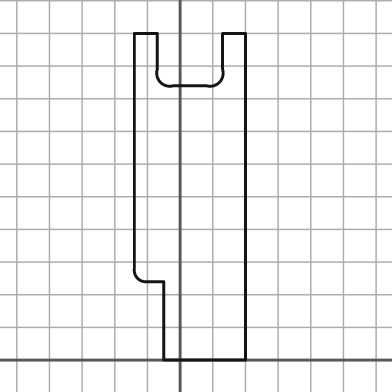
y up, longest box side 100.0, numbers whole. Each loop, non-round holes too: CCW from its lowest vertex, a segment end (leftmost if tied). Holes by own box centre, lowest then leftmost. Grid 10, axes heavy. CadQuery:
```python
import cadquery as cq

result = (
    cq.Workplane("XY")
    .moveTo(-5.0, 0.0)
    .lineTo(20.0, 0.0)
    .lineTo(20.0, 100.0)
    .lineTo(13.0, 100.0)
    .lineTo(13.0, 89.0)
    .threePointArc((12.0, 85.0), (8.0, 84.0))
    .lineTo(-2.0, 84.0)
    .threePointArc((-6.0, 85.0), (-7.0, 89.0))
    .lineTo(-7.0, 100.0)
    .lineTo(-14.0, 100.0)
    .lineTo(-14.0, 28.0)
    .threePointArc((-13.0, 25.0), (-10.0, 24.0))
    .lineTo(-5.0, 24.0)
    .close()
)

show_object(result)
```